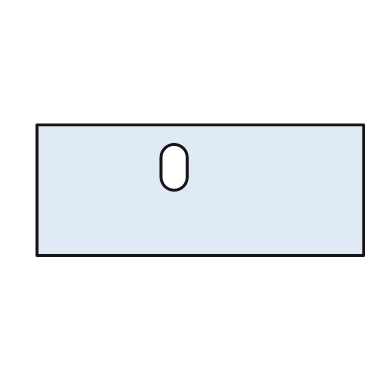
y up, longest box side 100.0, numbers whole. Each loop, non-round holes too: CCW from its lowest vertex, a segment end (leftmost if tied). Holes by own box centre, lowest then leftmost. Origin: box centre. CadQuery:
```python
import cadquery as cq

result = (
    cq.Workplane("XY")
    .moveTo(-50.0, -20.0)
    .lineTo(50.0, -20.0)
    .lineTo(50.0, 20.0)
    .lineTo(-50.0, 20.0)
    .close()
    .moveTo(-12.0, 4.0)
    .threePointArc((-8.0, 0.0), (-4.0, 4.0))
    .lineTo(-4.0, 10.0)
    .threePointArc((-8.0, 14.0), (-12.0, 10.0))
    .close()
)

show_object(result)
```